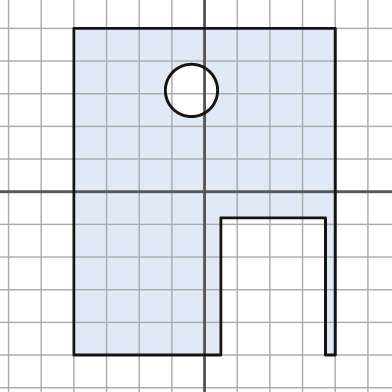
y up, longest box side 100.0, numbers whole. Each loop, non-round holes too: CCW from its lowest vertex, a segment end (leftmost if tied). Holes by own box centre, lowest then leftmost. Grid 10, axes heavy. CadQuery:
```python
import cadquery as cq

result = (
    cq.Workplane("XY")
    .moveTo(-40.0, -50.0)
    .lineTo(5.0, -50.0)
    .lineTo(5.0, -8.0)
    .lineTo(37.0, -8.0)
    .lineTo(37.0, -50.0)
    .lineTo(40.0, -50.0)
    .lineTo(40.0, 50.0)
    .lineTo(-40.0, 50.0)
    .close()
    .moveTo(-4.0, 31.0)
    .circle(8.0)
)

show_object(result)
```